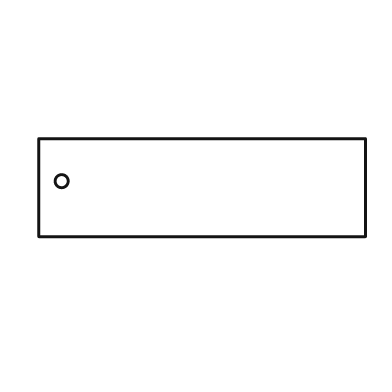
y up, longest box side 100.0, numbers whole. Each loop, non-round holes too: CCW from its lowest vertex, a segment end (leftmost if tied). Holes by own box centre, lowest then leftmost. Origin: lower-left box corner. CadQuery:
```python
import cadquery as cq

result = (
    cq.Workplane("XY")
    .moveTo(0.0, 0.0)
    .lineTo(100.0, 0.0)
    .lineTo(100.0, 30.0)
    .lineTo(0.0, 30.0)
    .close()
    .moveTo(7.0, 17.0)
    .circle(2.0)
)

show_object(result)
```